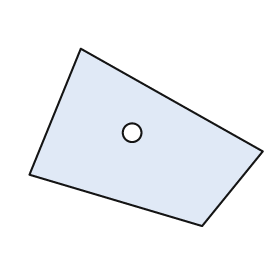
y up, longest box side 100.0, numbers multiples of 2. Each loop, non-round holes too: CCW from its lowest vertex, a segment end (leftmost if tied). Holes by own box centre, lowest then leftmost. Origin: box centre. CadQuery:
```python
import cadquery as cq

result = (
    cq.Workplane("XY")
    .moveTo(24.0, -38.0)
    .lineTo(50.0, -6.0)
    .lineTo(-28.0, 38.0)
    .lineTo(-50.0, -16.0)
    .close()
    .moveTo(-6.0, 2.0)
    .circle(4.0)
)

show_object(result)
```